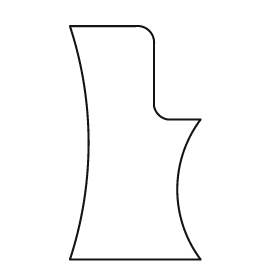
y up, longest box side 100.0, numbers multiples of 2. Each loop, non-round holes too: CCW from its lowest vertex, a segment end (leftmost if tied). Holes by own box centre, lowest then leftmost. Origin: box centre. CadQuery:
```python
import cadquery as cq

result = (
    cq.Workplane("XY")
    .moveTo(-28.0, -50.0)
    .lineTo(28.0, -50.0)
    .threePointArc((18.0, -20.0), (28.0, 10.0))
    .lineTo(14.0, 10.0)
    .threePointArc((10.0, 12.0), (8.0, 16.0))
    .lineTo(8.0, 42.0)
    .threePointArc((6.0, 48.0), (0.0, 50.0))
    .lineTo(-28.0, 50.0)
    .threePointArc((-20.0, 0.0), (-28.0, -50.0))
    .close()
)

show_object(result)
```